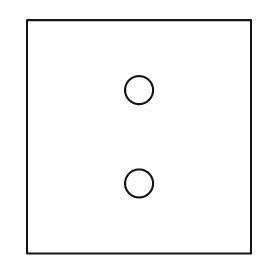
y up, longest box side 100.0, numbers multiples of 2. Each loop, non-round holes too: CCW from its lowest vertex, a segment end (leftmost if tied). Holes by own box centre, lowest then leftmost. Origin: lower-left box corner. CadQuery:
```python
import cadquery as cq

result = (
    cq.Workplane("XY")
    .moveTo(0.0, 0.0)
    .lineTo(96.0, 0.0)
    .lineTo(96.0, 100.0)
    .lineTo(0.0, 100.0)
    .close()
    .moveTo(48.0, 30.0)
    .circle(6.0)
    .moveTo(48.0, 70.0)
    .circle(6.0)
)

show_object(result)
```